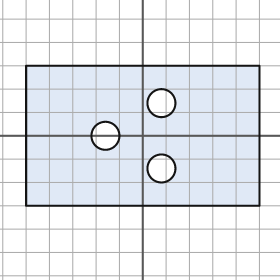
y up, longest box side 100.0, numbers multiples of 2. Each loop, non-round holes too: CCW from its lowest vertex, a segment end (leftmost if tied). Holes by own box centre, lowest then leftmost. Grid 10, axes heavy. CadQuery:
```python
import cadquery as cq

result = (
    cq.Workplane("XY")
    .moveTo(-50.0, -30.0)
    .lineTo(50.0, -30.0)
    .lineTo(50.0, 30.0)
    .lineTo(-50.0, 30.0)
    .close()
    .moveTo(8.0, -14.0)
    .circle(6.0)
    .moveTo(-16.0, 0.0)
    .circle(6.0)
    .moveTo(8.0, 14.0)
    .circle(6.0)
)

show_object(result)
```